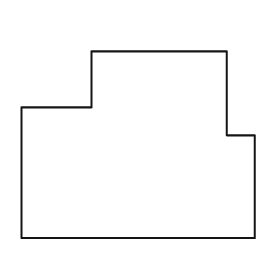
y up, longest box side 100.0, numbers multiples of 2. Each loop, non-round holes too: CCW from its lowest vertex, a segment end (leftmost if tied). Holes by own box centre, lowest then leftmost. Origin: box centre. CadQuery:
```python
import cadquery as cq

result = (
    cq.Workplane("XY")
    .moveTo(-50.0, -40.0)
    .lineTo(50.0, -40.0)
    .lineTo(50.0, 4.0)
    .lineTo(38.0, 4.0)
    .lineTo(38.0, 40.0)
    .lineTo(-20.0, 40.0)
    .lineTo(-20.0, 16.0)
    .lineTo(-50.0, 16.0)
    .close()
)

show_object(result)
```